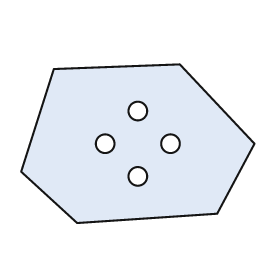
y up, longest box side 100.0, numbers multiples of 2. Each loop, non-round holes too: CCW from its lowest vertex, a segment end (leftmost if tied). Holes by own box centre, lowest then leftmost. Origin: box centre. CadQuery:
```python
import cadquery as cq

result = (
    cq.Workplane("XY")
    .moveTo(-26.0, -34.0)
    .lineTo(34.0, -30.0)
    .lineTo(50.0, 0.0)
    .lineTo(18.0, 34.0)
    .lineTo(-36.0, 32.0)
    .lineTo(-50.0, -12.0)
    .close()
    .moveTo(0.0, -14.0)
    .circle(4.0)
    .moveTo(-14.0, 0.0)
    .circle(4.0)
    .moveTo(14.0, 0.0)
    .circle(4.0)
    .moveTo(0.0, 14.0)
    .circle(4.0)
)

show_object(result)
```